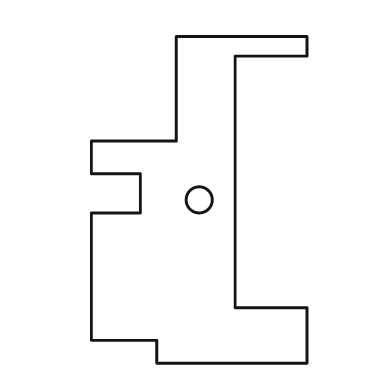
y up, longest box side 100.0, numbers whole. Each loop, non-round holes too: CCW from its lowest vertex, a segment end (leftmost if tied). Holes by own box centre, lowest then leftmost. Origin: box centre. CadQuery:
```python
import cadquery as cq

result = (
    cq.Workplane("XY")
    .moveTo(-13.0, -50.0)
    .lineTo(33.0, -50.0)
    .lineTo(33.0, -33.0)
    .lineTo(11.0, -33.0)
    .lineTo(11.0, 44.0)
    .lineTo(33.0, 44.0)
    .lineTo(33.0, 50.0)
    .lineTo(-7.0, 50.0)
    .lineTo(-7.0, 18.0)
    .lineTo(-33.0, 18.0)
    .lineTo(-33.0, 8.0)
    .lineTo(-18.0, 8.0)
    .lineTo(-18.0, -4.0)
    .lineTo(-33.0, -4.0)
    .lineTo(-33.0, -43.0)
    .lineTo(-13.0, -43.0)
    .close()
    .moveTo(0.0, 0.0)
    .circle(4.0)
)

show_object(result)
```